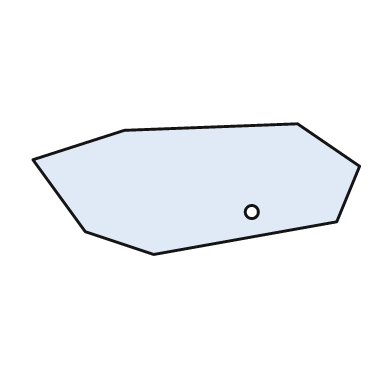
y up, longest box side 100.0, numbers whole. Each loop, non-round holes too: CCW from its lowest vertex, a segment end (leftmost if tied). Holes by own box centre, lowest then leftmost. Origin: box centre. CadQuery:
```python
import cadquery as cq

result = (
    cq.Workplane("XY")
    .moveTo(-13.0, -20.0)
    .lineTo(43.0, -10.0)
    .lineTo(50.0, 7.0)
    .lineTo(31.0, 20.0)
    .lineTo(-22.0, 18.0)
    .lineTo(-50.0, 9.0)
    .lineTo(-34.0, -13.0)
    .close()
    .moveTo(17.0, -7.0)
    .circle(2.0)
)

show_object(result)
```